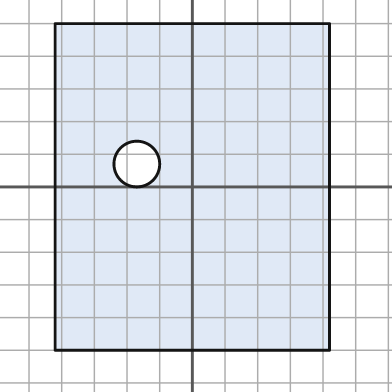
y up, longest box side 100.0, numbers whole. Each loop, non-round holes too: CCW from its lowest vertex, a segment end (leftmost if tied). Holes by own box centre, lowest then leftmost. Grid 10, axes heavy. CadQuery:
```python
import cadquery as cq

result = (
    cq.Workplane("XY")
    .moveTo(-42.0, -50.0)
    .lineTo(42.0, -50.0)
    .lineTo(42.0, 50.0)
    .lineTo(-42.0, 50.0)
    .close()
    .moveTo(-17.0, 7.0)
    .circle(7.0)
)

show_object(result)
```